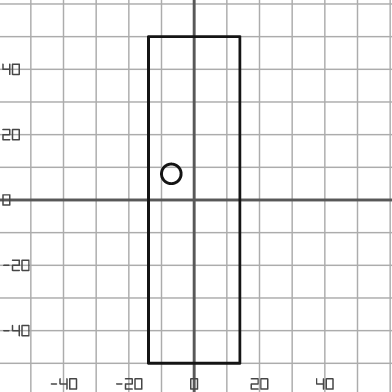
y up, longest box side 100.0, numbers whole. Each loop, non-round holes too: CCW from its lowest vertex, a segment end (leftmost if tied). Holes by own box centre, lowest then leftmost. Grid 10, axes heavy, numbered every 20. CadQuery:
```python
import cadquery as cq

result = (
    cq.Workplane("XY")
    .moveTo(-14.0, -50.0)
    .lineTo(14.0, -50.0)
    .lineTo(14.0, 50.0)
    .lineTo(-14.0, 50.0)
    .close()
    .moveTo(-7.0, 8.0)
    .circle(3.0)
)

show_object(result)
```